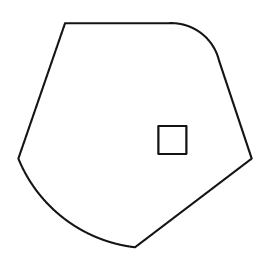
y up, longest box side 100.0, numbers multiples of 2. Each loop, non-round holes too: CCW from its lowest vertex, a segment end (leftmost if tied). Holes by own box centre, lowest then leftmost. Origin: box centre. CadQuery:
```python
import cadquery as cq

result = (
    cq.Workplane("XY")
    .moveTo(0.0, -48.0)
    .lineTo(50.0, -10.0)
    .lineTo(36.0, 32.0)
    .threePointArc((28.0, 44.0), (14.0, 48.0))
    .lineTo(-30.0, 48.0)
    .lineTo(-50.0, -10.0)
    .threePointArc((-30.0, -36.0), (0.0, -48.0))
    .close()
    .moveTo(10.0, -8.0)
    .lineTo(22.0, -8.0)
    .lineTo(22.0, 4.0)
    .lineTo(10.0, 4.0)
    .close()
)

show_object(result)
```